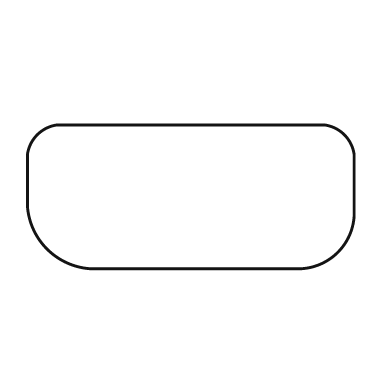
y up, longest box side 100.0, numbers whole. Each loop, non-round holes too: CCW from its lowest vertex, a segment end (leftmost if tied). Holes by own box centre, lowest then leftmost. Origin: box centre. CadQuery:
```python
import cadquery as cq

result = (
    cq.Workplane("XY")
    .moveTo(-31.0, -22.0)
    .lineTo(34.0, -22.0)
    .threePointArc((45.0, -17.0), (50.0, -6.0))
    .lineTo(50.0, 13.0)
    .threePointArc((47.0, 19.0), (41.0, 22.0))
    .lineTo(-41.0, 22.0)
    .threePointArc((-47.0, 19.0), (-50.0, 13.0))
    .lineTo(-50.0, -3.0)
    .threePointArc((-44.0, -16.0), (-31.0, -22.0))
    .close()
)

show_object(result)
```